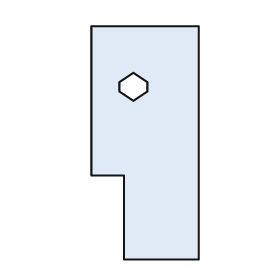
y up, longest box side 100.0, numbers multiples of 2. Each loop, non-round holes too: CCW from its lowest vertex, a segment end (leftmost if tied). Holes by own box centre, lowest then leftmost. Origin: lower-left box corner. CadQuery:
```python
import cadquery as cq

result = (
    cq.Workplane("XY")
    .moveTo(14.0, 0.0)
    .lineTo(46.0, 0.0)
    .lineTo(46.0, 100.0)
    .lineTo(0.0, 100.0)
    .lineTo(0.0, 36.0)
    .lineTo(14.0, 36.0)
    .close()
    .moveTo(18.0, 68.0)
    .lineTo(24.0, 72.0)
    .lineTo(24.0, 76.0)
    .lineTo(18.0, 80.0)
    .lineTo(12.0, 76.0)
    .lineTo(12.0, 72.0)
    .close()
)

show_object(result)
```